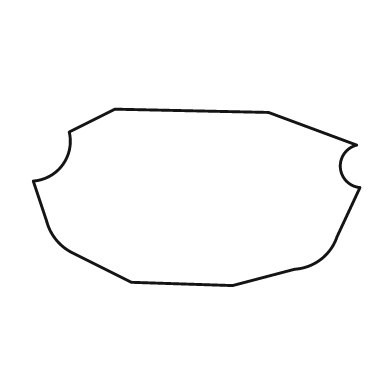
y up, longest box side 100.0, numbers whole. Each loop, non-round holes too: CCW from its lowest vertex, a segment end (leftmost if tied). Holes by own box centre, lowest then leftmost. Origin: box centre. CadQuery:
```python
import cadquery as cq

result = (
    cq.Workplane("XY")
    .moveTo(11.0, -27.0)
    .lineTo(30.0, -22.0)
    .threePointArc((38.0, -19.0), (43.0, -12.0))
    .lineTo(50.0, 3.0)
    .threePointArc((44.0, 9.0), (49.0, 16.0))
    .lineTo(22.0, 26.0)
    .lineTo(-25.0, 27.0)
    .lineTo(-39.0, 20.0)
    .threePointArc((-41.0, 10.0), (-50.0, 5.0))
    .lineTo(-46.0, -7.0)
    .threePointArc((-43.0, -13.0), (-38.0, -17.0))
    .lineTo(-20.0, -26.0)
    .close()
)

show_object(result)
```